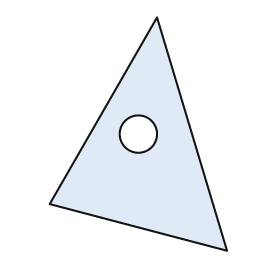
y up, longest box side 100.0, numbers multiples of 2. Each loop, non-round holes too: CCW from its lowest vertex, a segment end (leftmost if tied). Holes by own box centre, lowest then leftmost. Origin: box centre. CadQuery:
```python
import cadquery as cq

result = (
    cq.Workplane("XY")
    .moveTo(38.0, -50.0)
    .lineTo(8.0, 50.0)
    .lineTo(-38.0, -30.0)
    .close()
    .moveTo(0.0, 0.0)
    .circle(8.0)
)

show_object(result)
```